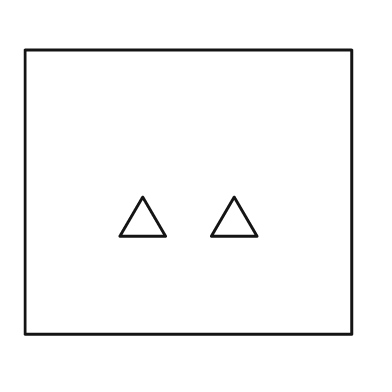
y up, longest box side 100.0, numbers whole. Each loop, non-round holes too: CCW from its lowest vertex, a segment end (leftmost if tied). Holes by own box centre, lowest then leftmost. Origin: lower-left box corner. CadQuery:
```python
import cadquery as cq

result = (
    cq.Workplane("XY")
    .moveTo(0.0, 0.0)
    .lineTo(100.0, 0.0)
    .lineTo(100.0, 87.0)
    .lineTo(0.0, 87.0)
    .close()
    .moveTo(29.0, 30.0)
    .lineTo(43.0, 30.0)
    .lineTo(36.0, 42.0)
    .close()
    .moveTo(57.0, 30.0)
    .lineTo(71.0, 30.0)
    .lineTo(64.0, 42.0)
    .close()
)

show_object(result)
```